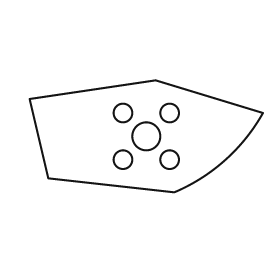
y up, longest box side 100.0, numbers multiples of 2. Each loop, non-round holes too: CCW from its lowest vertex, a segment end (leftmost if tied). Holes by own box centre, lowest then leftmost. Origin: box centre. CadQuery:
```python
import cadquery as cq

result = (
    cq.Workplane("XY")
    .moveTo(12.0, -24.0)
    .threePointArc((34.0, -10.0), (50.0, 10.0))
    .lineTo(4.0, 24.0)
    .lineTo(-50.0, 16.0)
    .lineTo(-42.0, -18.0)
    .close()
    .moveTo(-10.0, -10.0)
    .circle(4.0)
    .moveTo(10.0, -10.0)
    .circle(4.0)
    .moveTo(0.0, 0.0)
    .circle(6.0)
    .moveTo(-10.0, 10.0)
    .circle(4.0)
    .moveTo(10.0, 10.0)
    .circle(4.0)
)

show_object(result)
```